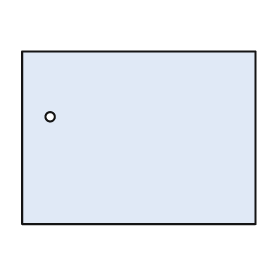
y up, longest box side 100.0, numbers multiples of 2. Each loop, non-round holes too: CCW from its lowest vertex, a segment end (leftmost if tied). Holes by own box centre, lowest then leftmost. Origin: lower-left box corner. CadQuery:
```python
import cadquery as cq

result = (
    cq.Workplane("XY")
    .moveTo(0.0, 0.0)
    .lineTo(100.0, 0.0)
    .lineTo(100.0, 74.0)
    .lineTo(0.0, 74.0)
    .close()
    .moveTo(12.0, 46.0)
    .circle(2.0)
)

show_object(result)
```